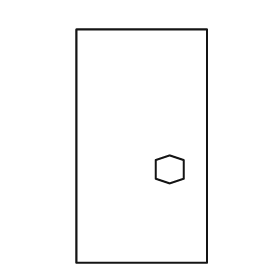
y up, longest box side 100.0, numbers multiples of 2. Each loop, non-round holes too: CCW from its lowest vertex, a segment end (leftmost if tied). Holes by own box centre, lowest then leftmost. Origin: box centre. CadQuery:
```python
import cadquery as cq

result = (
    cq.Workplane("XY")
    .moveTo(-28.0, -50.0)
    .lineTo(28.0, -50.0)
    .lineTo(28.0, 50.0)
    .lineTo(-28.0, 50.0)
    .close()
    .moveTo(12.0, -16.0)
    .lineTo(18.0, -14.0)
    .lineTo(18.0, -6.0)
    .lineTo(12.0, -4.0)
    .lineTo(6.0, -6.0)
    .lineTo(6.0, -14.0)
    .close()
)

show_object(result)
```